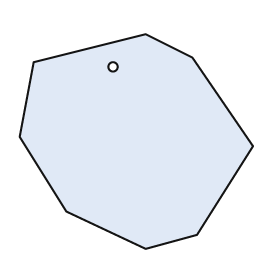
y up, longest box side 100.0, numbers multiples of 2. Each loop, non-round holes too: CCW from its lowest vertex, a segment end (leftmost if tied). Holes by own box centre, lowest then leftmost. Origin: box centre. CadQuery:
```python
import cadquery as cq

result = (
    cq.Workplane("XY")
    .moveTo(4.0, -46.0)
    .lineTo(26.0, -40.0)
    .lineTo(50.0, -2.0)
    .lineTo(24.0, 36.0)
    .lineTo(4.0, 46.0)
    .lineTo(-44.0, 34.0)
    .lineTo(-50.0, 2.0)
    .lineTo(-30.0, -30.0)
    .close()
    .moveTo(-10.0, 32.0)
    .circle(2.0)
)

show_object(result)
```